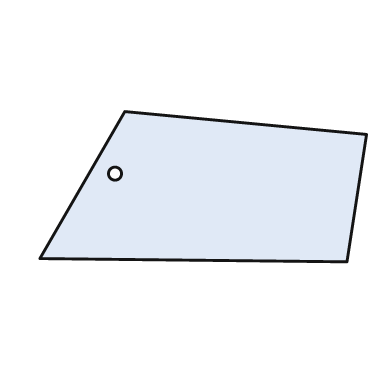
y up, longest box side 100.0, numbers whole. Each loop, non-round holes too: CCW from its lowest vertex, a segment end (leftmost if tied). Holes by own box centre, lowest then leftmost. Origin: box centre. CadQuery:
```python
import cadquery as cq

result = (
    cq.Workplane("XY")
    .moveTo(44.0, -23.0)
    .lineTo(50.0, 16.0)
    .lineTo(-24.0, 23.0)
    .lineTo(-50.0, -22.0)
    .close()
    .moveTo(-27.0, 4.0)
    .circle(2.0)
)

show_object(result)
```